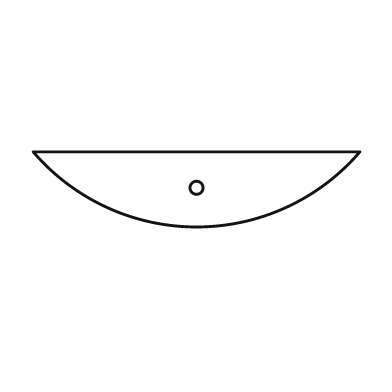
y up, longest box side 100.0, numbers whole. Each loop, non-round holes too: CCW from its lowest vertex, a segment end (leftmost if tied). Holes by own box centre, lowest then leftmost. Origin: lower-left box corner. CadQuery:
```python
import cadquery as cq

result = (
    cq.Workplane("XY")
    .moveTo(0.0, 23.0)
    .threePointArc((50.0, 0.0), (100.0, 23.0))
    .close()
    .moveTo(50.0, 12.0)
    .circle(2.0)
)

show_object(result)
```